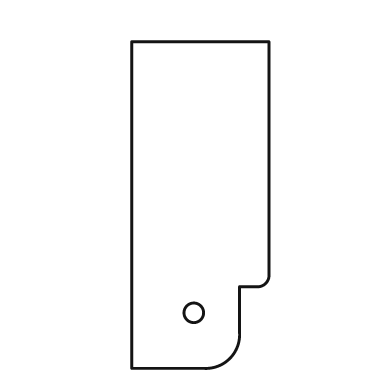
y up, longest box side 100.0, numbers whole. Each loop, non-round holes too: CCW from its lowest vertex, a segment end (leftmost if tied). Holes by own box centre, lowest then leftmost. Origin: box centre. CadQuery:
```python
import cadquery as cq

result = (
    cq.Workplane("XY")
    .moveTo(-21.0, -50.0)
    .lineTo(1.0, -50.0)
    .threePointArc((9.0, -47.0), (12.0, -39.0))
    .lineTo(12.0, -25.0)
    .lineTo(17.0, -25.0)
    .threePointArc((20.0, -24.0), (21.0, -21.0))
    .lineTo(21.0, 50.0)
    .lineTo(-21.0, 50.0)
    .close()
    .moveTo(-2.0, -33.0)
    .circle(3.0)
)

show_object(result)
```